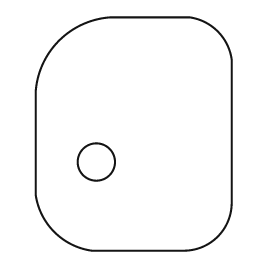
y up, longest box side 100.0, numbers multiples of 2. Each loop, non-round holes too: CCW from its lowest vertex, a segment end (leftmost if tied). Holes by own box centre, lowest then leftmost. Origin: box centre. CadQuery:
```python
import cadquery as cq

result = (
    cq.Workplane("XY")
    .moveTo(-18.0, -50.0)
    .lineTo(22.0, -50.0)
    .threePointArc((36.0, -44.0), (42.0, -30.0))
    .lineTo(42.0, 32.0)
    .threePointArc((36.0, 44.0), (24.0, 50.0))
    .lineTo(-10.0, 50.0)
    .threePointArc((-32.0, 40.0), (-42.0, 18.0))
    .lineTo(-42.0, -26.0)
    .threePointArc((-34.0, -42.0), (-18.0, -50.0))
    .close()
    .moveTo(-16.0, -12.0)
    .circle(8.0)
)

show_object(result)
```